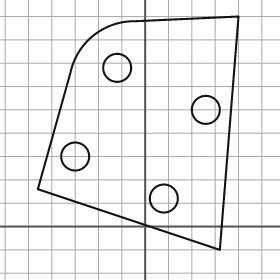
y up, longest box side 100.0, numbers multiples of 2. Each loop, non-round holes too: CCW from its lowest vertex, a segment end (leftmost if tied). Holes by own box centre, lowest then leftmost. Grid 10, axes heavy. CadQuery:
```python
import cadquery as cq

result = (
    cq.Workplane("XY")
    .moveTo(32.0, -10.0)
    .lineTo(40.0, 90.0)
    .lineTo(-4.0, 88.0)
    .threePointArc((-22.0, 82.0), (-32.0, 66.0))
    .lineTo(-46.0, 16.0)
    .close()
    .moveTo(8.0, 12.0)
    .circle(6.0)
    .moveTo(-30.0, 30.0)
    .circle(6.0)
    .moveTo(26.0, 50.0)
    .circle(6.0)
    .moveTo(-12.0, 68.0)
    .circle(6.0)
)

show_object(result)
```